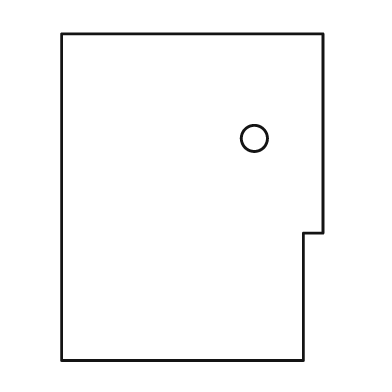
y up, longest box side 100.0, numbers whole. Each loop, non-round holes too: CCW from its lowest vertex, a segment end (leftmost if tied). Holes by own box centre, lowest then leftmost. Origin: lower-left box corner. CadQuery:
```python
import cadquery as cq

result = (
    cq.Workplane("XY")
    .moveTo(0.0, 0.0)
    .lineTo(74.0, 0.0)
    .lineTo(74.0, 39.0)
    .lineTo(80.0, 39.0)
    .lineTo(80.0, 100.0)
    .lineTo(0.0, 100.0)
    .close()
    .moveTo(59.0, 68.0)
    .circle(4.0)
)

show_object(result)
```